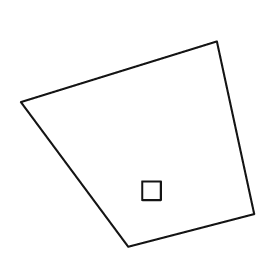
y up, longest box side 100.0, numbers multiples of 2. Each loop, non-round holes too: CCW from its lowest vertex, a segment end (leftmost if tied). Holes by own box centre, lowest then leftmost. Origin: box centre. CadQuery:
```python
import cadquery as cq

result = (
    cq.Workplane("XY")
    .moveTo(-4.0, -44.0)
    .lineTo(50.0, -30.0)
    .lineTo(34.0, 44.0)
    .lineTo(-50.0, 18.0)
    .close()
    .moveTo(2.0, -24.0)
    .lineTo(10.0, -24.0)
    .lineTo(10.0, -16.0)
    .lineTo(2.0, -16.0)
    .close()
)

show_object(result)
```